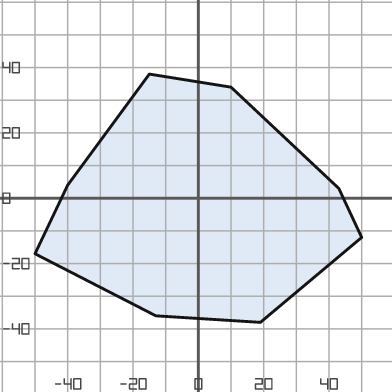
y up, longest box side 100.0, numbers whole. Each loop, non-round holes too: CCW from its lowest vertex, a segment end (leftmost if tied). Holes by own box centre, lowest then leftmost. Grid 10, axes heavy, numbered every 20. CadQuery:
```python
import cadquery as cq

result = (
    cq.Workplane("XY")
    .moveTo(19.0, -38.0)
    .lineTo(50.0, -12.0)
    .lineTo(43.0, 3.0)
    .lineTo(10.0, 34.0)
    .lineTo(-15.0, 38.0)
    .lineTo(-40.0, 4.0)
    .lineTo(-50.0, -17.0)
    .lineTo(-13.0, -36.0)
    .close()
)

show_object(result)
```